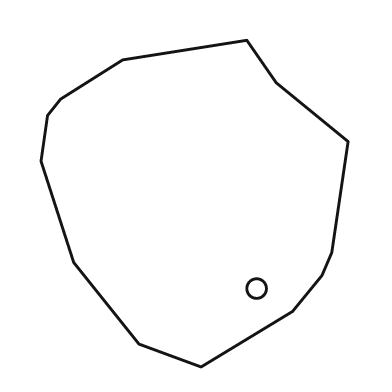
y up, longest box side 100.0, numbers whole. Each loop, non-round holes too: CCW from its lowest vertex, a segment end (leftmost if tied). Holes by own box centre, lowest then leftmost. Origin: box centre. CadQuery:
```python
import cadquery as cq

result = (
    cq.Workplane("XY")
    .moveTo(2.0, -50.0)
    .lineTo(30.0, -33.0)
    .lineTo(39.0, -22.0)
    .lineTo(42.0, -15.0)
    .lineTo(47.0, 19.0)
    .lineTo(25.0, 37.0)
    .lineTo(16.0, 50.0)
    .lineTo(-22.0, 44.0)
    .lineTo(-41.0, 32.0)
    .lineTo(-45.0, 27.0)
    .lineTo(-47.0, 13.0)
    .lineTo(-37.0, -18.0)
    .lineTo(-17.0, -43.0)
    .close()
    .moveTo(19.0, -26.0)
    .circle(3.0)
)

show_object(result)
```